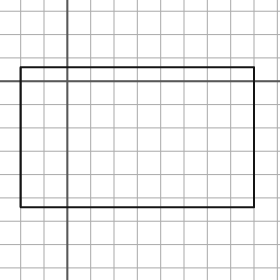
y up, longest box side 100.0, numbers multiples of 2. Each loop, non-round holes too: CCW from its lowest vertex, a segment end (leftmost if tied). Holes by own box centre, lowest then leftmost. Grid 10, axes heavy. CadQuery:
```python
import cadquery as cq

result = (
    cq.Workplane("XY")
    .moveTo(-20.0, -54.0)
    .lineTo(80.0, -54.0)
    .lineTo(80.0, 6.0)
    .lineTo(-20.0, 6.0)
    .close()
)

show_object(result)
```